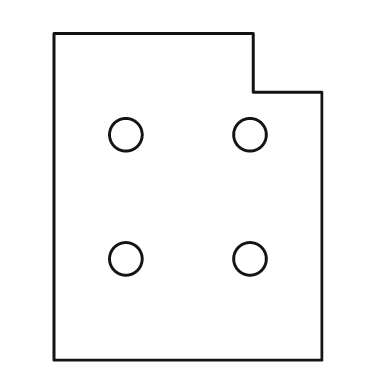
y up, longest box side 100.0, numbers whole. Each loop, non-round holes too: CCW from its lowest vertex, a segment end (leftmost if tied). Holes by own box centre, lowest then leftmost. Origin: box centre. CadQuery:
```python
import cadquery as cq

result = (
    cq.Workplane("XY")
    .moveTo(-41.0, -50.0)
    .lineTo(41.0, -50.0)
    .lineTo(41.0, 32.0)
    .lineTo(20.0, 32.0)
    .lineTo(20.0, 50.0)
    .lineTo(-41.0, 50.0)
    .close()
    .moveTo(-19.0, -19.0)
    .circle(5.0)
    .moveTo(19.0, -19.0)
    .circle(5.0)
    .moveTo(-19.0, 19.0)
    .circle(5.0)
    .moveTo(19.0, 19.0)
    .circle(5.0)
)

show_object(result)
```